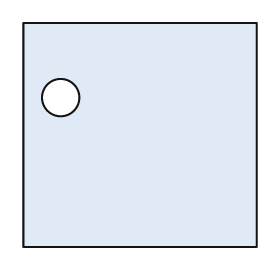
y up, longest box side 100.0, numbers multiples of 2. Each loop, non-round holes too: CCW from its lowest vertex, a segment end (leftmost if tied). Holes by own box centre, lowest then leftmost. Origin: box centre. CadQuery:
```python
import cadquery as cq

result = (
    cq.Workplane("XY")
    .moveTo(-50.0, -48.0)
    .lineTo(50.0, -48.0)
    .lineTo(50.0, 48.0)
    .lineTo(-50.0, 48.0)
    .close()
    .moveTo(-34.0, 16.0)
    .circle(8.0)
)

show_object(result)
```